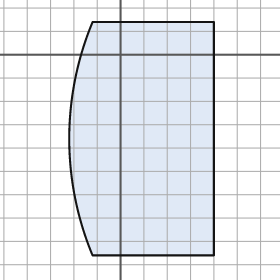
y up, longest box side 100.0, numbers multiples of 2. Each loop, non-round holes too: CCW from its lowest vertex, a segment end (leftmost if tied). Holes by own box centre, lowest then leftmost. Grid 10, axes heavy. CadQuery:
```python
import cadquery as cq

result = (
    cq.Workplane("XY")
    .moveTo(-12.0, -86.0)
    .lineTo(40.0, -86.0)
    .lineTo(40.0, 14.0)
    .lineTo(-12.0, 14.0)
    .threePointArc((-22.0, -36.0), (-12.0, -86.0))
    .close()
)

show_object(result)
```